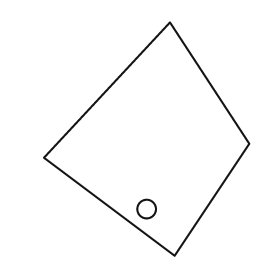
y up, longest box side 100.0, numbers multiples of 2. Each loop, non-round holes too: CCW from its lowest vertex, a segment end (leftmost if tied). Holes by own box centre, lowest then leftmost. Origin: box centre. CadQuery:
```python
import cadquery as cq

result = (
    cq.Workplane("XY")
    .moveTo(12.0, -50.0)
    .lineTo(44.0, -2.0)
    .lineTo(10.0, 50.0)
    .lineTo(-44.0, -8.0)
    .close()
    .moveTo(0.0, -30.0)
    .circle(4.0)
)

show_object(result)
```